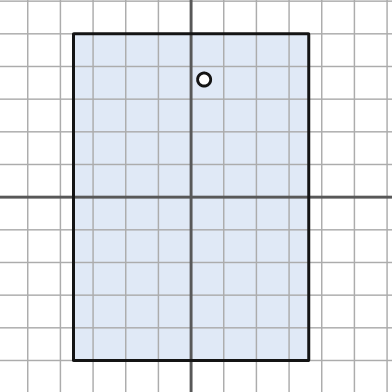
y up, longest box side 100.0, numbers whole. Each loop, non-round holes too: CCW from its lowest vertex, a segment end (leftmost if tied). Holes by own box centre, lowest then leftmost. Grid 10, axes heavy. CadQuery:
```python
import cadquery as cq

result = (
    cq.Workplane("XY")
    .moveTo(-36.0, -50.0)
    .lineTo(36.0, -50.0)
    .lineTo(36.0, 50.0)
    .lineTo(-36.0, 50.0)
    .close()
    .moveTo(4.0, 36.0)
    .circle(2.0)
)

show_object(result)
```